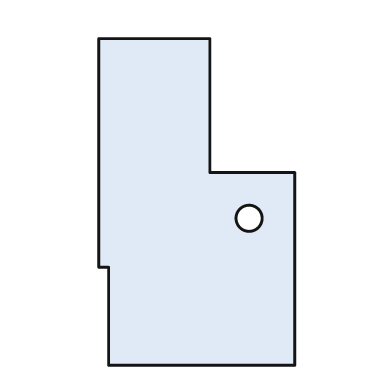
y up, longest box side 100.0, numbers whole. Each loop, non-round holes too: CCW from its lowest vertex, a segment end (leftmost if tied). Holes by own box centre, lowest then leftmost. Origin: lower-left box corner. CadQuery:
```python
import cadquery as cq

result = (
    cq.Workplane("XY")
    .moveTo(3.0, 0.0)
    .lineTo(60.0, 0.0)
    .lineTo(60.0, 59.0)
    .lineTo(34.0, 59.0)
    .lineTo(34.0, 100.0)
    .lineTo(0.0, 100.0)
    .lineTo(0.0, 30.0)
    .lineTo(3.0, 30.0)
    .close()
    .moveTo(46.0, 45.0)
    .circle(4.0)
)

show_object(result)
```